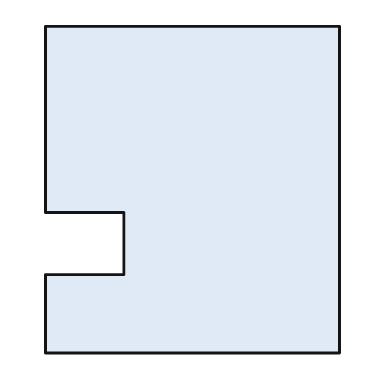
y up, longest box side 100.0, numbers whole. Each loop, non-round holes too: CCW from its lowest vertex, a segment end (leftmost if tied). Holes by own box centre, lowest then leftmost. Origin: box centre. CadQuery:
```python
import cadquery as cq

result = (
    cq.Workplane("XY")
    .moveTo(-45.0, -50.0)
    .lineTo(45.0, -50.0)
    .lineTo(45.0, 50.0)
    .lineTo(-45.0, 50.0)
    .lineTo(-45.0, -7.0)
    .lineTo(-21.0, -7.0)
    .lineTo(-21.0, -26.0)
    .lineTo(-45.0, -26.0)
    .close()
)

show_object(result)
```